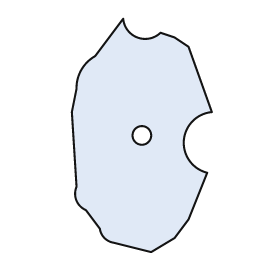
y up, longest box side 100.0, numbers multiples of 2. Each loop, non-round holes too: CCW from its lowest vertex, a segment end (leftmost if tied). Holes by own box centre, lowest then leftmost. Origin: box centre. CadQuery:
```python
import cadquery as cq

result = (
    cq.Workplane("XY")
    .moveTo(4.0, -50.0)
    .lineTo(14.0, -44.0)
    .lineTo(20.0, -36.0)
    .lineTo(28.0, -16.0)
    .threePointArc((18.0, -2.0), (30.0, 10.0))
    .lineTo(20.0, 38.0)
    .lineTo(14.0, 42.0)
    .lineTo(8.0, 44.0)
    .threePointArc((-2.0, 42.0), (-8.0, 50.0))
    .lineTo(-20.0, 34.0)
    .threePointArc((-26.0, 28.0), (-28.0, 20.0))
    .lineTo(-30.0, 10.0)
    .lineTo(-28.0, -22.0)
    .threePointArc((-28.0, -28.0), (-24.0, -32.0))
    .lineTo(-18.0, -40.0)
    .threePointArc((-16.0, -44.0), (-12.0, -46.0))
    .close()
    .moveTo(0.0, 0.0)
    .circle(4.0)
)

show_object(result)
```